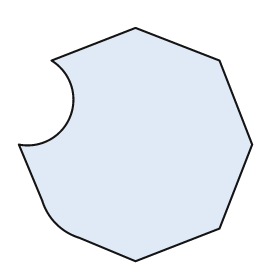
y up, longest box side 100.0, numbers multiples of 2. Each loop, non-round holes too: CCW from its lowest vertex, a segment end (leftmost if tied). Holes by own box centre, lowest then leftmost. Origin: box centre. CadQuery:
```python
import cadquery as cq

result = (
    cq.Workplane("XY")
    .moveTo(0.0, -50.0)
    .lineTo(36.0, -36.0)
    .lineTo(50.0, 0.0)
    .lineTo(36.0, 36.0)
    .lineTo(0.0, 50.0)
    .lineTo(-36.0, 36.0)
    .threePointArc((-28.0, 12.0), (-50.0, 0.0))
    .lineTo(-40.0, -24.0)
    .threePointArc((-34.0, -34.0), (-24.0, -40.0))
    .close()
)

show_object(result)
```